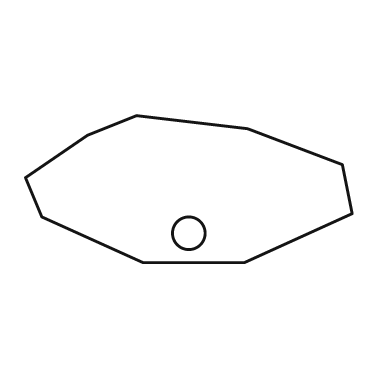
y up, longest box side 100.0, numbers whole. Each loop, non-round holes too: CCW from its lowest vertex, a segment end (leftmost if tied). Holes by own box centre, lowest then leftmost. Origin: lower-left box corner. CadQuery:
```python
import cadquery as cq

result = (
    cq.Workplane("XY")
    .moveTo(36.0, 0.0)
    .lineTo(67.0, 0.0)
    .lineTo(100.0, 15.0)
    .lineTo(97.0, 30.0)
    .lineTo(68.0, 41.0)
    .lineTo(34.0, 45.0)
    .lineTo(19.0, 39.0)
    .lineTo(0.0, 26.0)
    .lineTo(5.0, 14.0)
    .close()
    .moveTo(50.0, 9.0)
    .circle(5.0)
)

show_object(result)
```